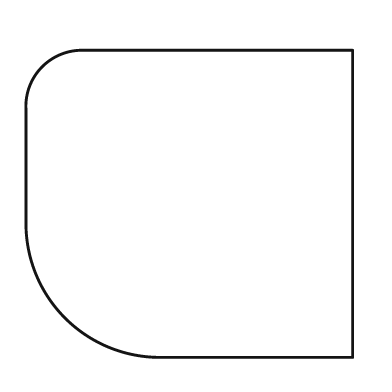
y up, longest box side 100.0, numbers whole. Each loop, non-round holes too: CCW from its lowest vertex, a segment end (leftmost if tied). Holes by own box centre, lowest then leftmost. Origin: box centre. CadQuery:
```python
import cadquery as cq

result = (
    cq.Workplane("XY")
    .moveTo(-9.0, -47.0)
    .lineTo(50.0, -47.0)
    .lineTo(50.0, 47.0)
    .lineTo(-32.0, 47.0)
    .threePointArc((-45.0, 42.0), (-50.0, 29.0))
    .lineTo(-50.0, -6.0)
    .threePointArc((-38.0, -35.0), (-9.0, -47.0))
    .close()
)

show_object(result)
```